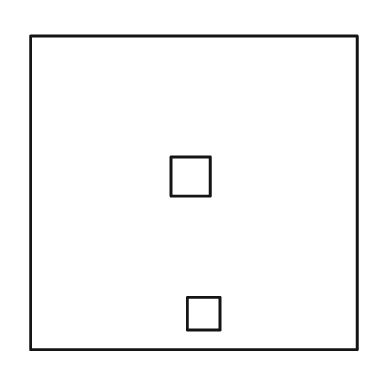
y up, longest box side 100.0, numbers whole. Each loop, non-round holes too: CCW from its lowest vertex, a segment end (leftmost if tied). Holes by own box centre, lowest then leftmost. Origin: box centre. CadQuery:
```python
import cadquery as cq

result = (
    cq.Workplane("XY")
    .moveTo(-50.0, -48.0)
    .lineTo(50.0, -48.0)
    .lineTo(50.0, 48.0)
    .lineTo(-50.0, 48.0)
    .close()
    .moveTo(-2.0, -42.0)
    .lineTo(8.0, -42.0)
    .lineTo(8.0, -32.0)
    .lineTo(-2.0, -32.0)
    .close()
    .moveTo(-7.0, -1.0)
    .lineTo(5.0, -1.0)
    .lineTo(5.0, 11.0)
    .lineTo(-7.0, 11.0)
    .close()
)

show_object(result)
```